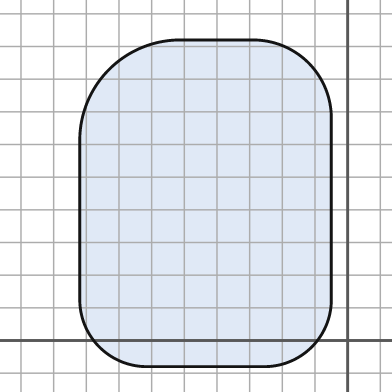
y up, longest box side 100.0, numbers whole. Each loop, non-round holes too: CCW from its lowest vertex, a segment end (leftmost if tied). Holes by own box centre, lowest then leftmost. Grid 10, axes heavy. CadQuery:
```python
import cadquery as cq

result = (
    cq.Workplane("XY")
    .moveTo(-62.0, -8.0)
    .lineTo(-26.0, -8.0)
    .threePointArc((-11.0, -2.0), (-5.0, 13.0))
    .lineTo(-5.0, 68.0)
    .threePointArc((-12.0, 85.0), (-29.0, 92.0))
    .lineTo(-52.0, 92.0)
    .threePointArc((-73.0, 83.0), (-82.0, 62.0))
    .lineTo(-82.0, 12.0)
    .threePointArc((-76.0, -2.0), (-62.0, -8.0))
    .close()
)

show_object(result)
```